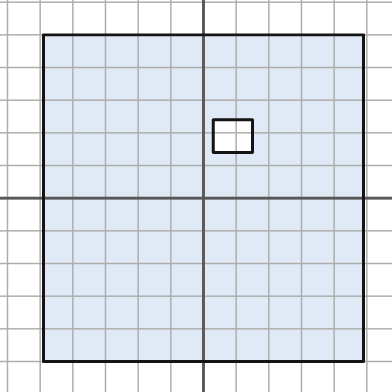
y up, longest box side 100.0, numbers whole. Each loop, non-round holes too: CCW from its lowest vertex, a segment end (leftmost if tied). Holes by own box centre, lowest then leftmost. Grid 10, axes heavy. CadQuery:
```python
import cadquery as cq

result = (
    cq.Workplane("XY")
    .moveTo(-49.0, -50.0)
    .lineTo(49.0, -50.0)
    .lineTo(49.0, 50.0)
    .lineTo(-49.0, 50.0)
    .close()
    .moveTo(3.0, 14.0)
    .lineTo(15.0, 14.0)
    .lineTo(15.0, 24.0)
    .lineTo(3.0, 24.0)
    .close()
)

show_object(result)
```